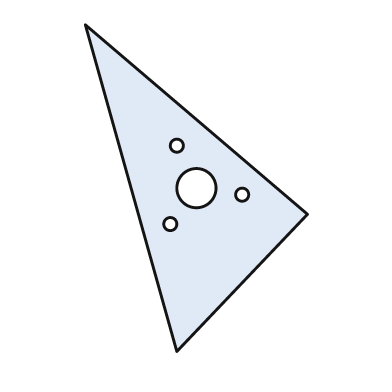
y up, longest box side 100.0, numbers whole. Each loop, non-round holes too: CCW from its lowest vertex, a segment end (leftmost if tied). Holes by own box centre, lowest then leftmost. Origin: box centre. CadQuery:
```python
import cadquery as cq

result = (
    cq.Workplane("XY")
    .moveTo(-6.0, -50.0)
    .lineTo(34.0, -8.0)
    .lineTo(-34.0, 50.0)
    .close()
    .moveTo(-8.0, -11.0)
    .circle(2.0)
    .moveTo(14.0, -2.0)
    .circle(2.0)
    .moveTo(0.0, 0.0)
    .circle(6.0)
    .moveTo(-6.0, 13.0)
    .circle(2.0)
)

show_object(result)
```